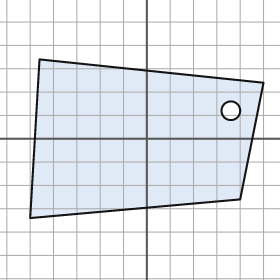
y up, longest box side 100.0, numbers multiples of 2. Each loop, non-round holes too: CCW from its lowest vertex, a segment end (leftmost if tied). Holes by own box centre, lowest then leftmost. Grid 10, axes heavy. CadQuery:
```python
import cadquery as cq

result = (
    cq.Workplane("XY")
    .moveTo(-50.0, -34.0)
    .lineTo(40.0, -26.0)
    .lineTo(50.0, 24.0)
    .lineTo(-46.0, 34.0)
    .close()
    .moveTo(36.0, 12.0)
    .circle(4.0)
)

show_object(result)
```